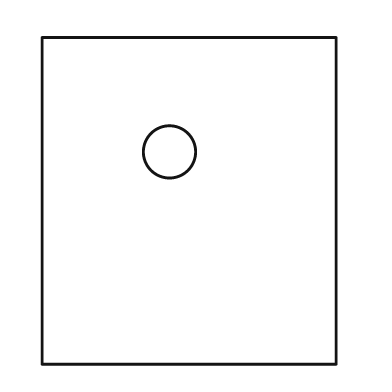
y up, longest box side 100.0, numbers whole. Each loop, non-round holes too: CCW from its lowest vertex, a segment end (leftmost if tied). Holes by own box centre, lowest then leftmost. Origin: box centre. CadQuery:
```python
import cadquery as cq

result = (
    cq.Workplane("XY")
    .moveTo(-45.0, -50.0)
    .lineTo(45.0, -50.0)
    .lineTo(45.0, 50.0)
    .lineTo(-45.0, 50.0)
    .close()
    .moveTo(-6.0, 15.0)
    .circle(8.0)
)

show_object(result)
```